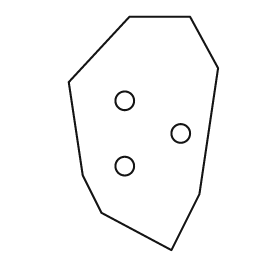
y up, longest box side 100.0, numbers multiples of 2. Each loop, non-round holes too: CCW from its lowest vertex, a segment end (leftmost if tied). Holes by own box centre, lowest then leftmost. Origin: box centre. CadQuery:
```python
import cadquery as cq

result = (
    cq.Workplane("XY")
    .moveTo(12.0, -50.0)
    .lineTo(24.0, -26.0)
    .lineTo(32.0, 28.0)
    .lineTo(20.0, 50.0)
    .lineTo(-6.0, 50.0)
    .lineTo(-32.0, 22.0)
    .lineTo(-26.0, -18.0)
    .lineTo(-18.0, -34.0)
    .close()
    .moveTo(-8.0, -14.0)
    .circle(4.0)
    .moveTo(16.0, 0.0)
    .circle(4.0)
    .moveTo(-8.0, 14.0)
    .circle(4.0)
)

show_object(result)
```